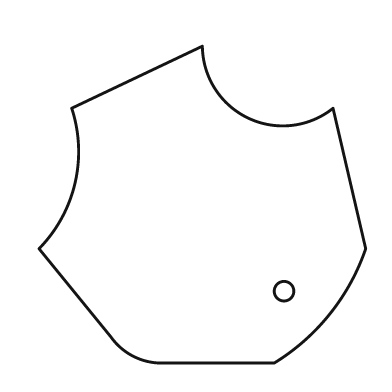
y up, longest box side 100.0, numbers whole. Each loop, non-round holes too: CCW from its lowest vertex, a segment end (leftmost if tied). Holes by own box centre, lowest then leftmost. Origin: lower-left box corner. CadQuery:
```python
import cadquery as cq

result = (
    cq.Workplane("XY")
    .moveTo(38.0, 0.0)
    .lineTo(72.0, 0.0)
    .threePointArc((89.0, 15.0), (100.0, 35.0))
    .lineTo(90.0, 78.0)
    .threePointArc((64.0, 75.0), (50.0, 97.0))
    .lineTo(10.0, 78.0)
    .threePointArc((11.0, 55.0), (0.0, 35.0))
    .lineTo(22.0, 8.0)
    .threePointArc((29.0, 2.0), (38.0, 0.0))
    .close()
    .moveTo(75.0, 22.0)
    .circle(3.0)
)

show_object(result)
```